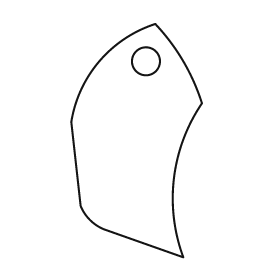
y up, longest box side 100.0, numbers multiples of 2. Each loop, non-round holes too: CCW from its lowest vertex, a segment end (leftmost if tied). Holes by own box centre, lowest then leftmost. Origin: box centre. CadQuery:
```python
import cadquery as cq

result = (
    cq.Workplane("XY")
    .moveTo(20.0, -50.0)
    .threePointArc((16.0, -16.0), (28.0, 16.0))
    .threePointArc((20.0, 34.0), (8.0, 50.0))
    .threePointArc((-16.0, 34.0), (-28.0, 8.0))
    .lineTo(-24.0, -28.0)
    .threePointArc((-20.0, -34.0), (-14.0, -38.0))
    .close()
    .moveTo(4.0, 34.0)
    .circle(6.0)
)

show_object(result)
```